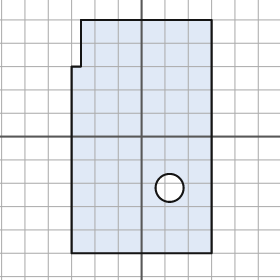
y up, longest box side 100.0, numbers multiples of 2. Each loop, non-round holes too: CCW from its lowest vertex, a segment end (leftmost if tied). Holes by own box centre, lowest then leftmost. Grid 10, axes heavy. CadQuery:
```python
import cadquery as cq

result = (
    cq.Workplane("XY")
    .moveTo(-30.0, -50.0)
    .lineTo(30.0, -50.0)
    .lineTo(30.0, 50.0)
    .lineTo(-26.0, 50.0)
    .lineTo(-26.0, 30.0)
    .lineTo(-30.0, 30.0)
    .close()
    .moveTo(12.0, -22.0)
    .circle(6.0)
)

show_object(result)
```